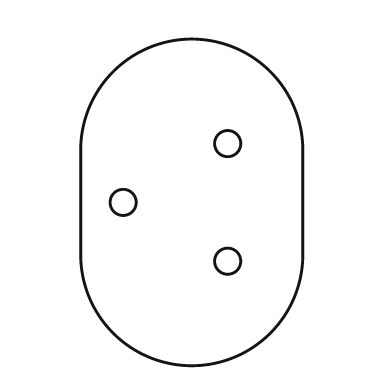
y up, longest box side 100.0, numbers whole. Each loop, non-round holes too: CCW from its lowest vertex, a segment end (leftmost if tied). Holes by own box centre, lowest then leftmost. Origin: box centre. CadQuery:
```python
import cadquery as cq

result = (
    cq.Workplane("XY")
    .moveTo(-34.0, -16.0)
    .threePointArc((0.0, -50.0), (34.0, -16.0))
    .lineTo(34.0, 16.0)
    .threePointArc((0.0, 50.0), (-34.0, 16.0))
    .close()
    .moveTo(11.0, -18.0)
    .circle(4.0)
    .moveTo(-21.0, 0.0)
    .circle(4.0)
    .moveTo(11.0, 18.0)
    .circle(4.0)
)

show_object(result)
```